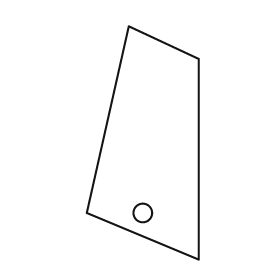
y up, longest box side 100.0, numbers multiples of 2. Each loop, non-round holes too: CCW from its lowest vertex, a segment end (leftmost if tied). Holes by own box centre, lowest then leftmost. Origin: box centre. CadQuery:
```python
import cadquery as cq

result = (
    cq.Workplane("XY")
    .moveTo(24.0, -50.0)
    .lineTo(24.0, 36.0)
    .lineTo(-6.0, 50.0)
    .lineTo(-24.0, -30.0)
    .close()
    .moveTo(0.0, -30.0)
    .circle(4.0)
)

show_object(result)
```